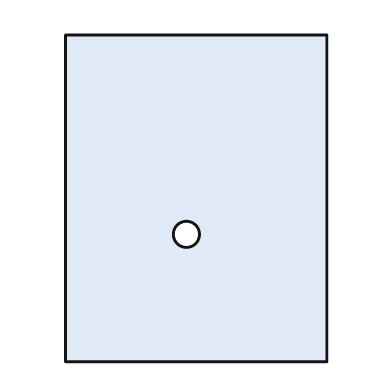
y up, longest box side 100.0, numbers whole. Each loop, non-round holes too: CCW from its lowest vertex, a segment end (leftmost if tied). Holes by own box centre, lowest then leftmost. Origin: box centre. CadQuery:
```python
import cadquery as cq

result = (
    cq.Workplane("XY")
    .moveTo(-40.0, -50.0)
    .lineTo(40.0, -50.0)
    .lineTo(40.0, 50.0)
    .lineTo(-40.0, 50.0)
    .close()
    .moveTo(-3.0, -11.0)
    .circle(4.0)
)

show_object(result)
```